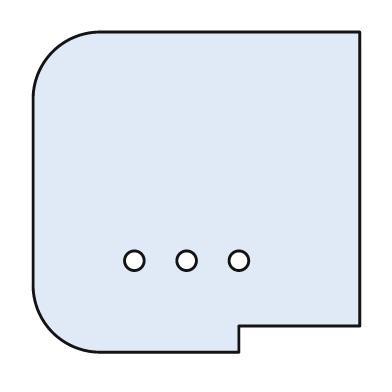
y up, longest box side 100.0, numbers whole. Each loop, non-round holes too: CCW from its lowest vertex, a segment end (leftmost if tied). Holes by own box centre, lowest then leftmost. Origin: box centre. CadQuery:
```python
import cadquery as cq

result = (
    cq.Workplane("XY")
    .moveTo(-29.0, -49.0)
    .lineTo(13.0, -49.0)
    .lineTo(13.0, -41.0)
    .lineTo(50.0, -41.0)
    .lineTo(50.0, 49.0)
    .lineTo(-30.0, 49.0)
    .threePointArc((-44.0, 43.0), (-50.0, 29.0))
    .lineTo(-50.0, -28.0)
    .threePointArc((-44.0, -43.0), (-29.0, -49.0))
    .close()
    .moveTo(-19.0, -21.0)
    .circle(3.0)
    .moveTo(-3.0, -21.0)
    .circle(3.0)
    .moveTo(13.0, -21.0)
    .circle(3.0)
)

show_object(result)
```